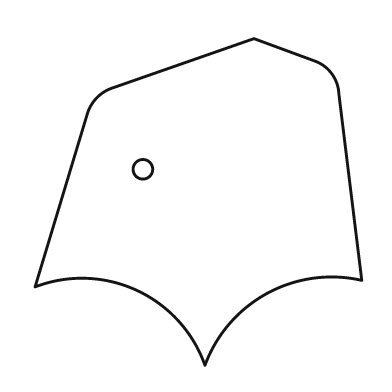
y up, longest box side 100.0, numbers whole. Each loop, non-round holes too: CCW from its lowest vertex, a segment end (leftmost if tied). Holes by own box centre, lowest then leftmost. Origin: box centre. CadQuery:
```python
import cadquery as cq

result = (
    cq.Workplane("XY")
    .moveTo(2.0, -50.0)
    .threePointArc((21.0, -28.0), (50.0, -24.0))
    .lineTo(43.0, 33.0)
    .threePointArc((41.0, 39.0), (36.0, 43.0))
    .lineTo(17.0, 50.0)
    .lineTo(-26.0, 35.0)
    .threePointArc((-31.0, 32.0), (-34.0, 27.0))
    .lineTo(-50.0, -26.0)
    .threePointArc((-19.0, -27.0), (2.0, -50.0))
    .close()
    .moveTo(-17.0, 10.0)
    .circle(3.0)
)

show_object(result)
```